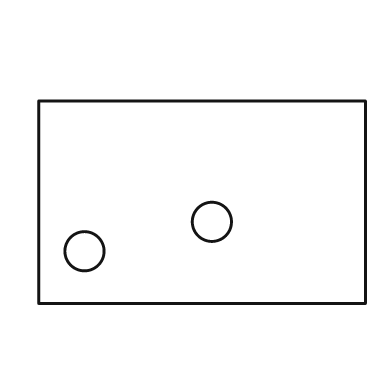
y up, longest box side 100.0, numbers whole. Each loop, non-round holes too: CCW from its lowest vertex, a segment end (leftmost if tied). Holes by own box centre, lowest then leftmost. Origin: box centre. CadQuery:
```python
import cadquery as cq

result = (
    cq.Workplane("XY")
    .moveTo(-50.0, -31.0)
    .lineTo(50.0, -31.0)
    .lineTo(50.0, 31.0)
    .lineTo(-50.0, 31.0)
    .close()
    .moveTo(-36.0, -15.0)
    .circle(6.0)
    .moveTo(3.0, -6.0)
    .circle(6.0)
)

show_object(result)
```